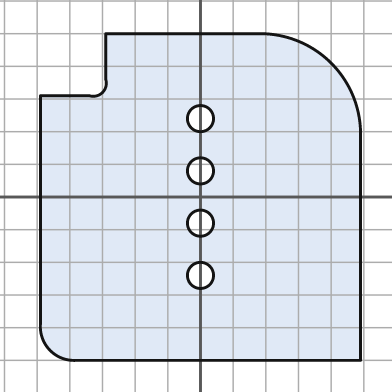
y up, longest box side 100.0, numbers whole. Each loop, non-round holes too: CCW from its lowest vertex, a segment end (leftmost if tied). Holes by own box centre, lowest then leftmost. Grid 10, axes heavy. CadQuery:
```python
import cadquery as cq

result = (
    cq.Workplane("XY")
    .moveTo(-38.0, -50.0)
    .lineTo(49.0, -50.0)
    .lineTo(49.0, 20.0)
    .threePointArc((40.0, 41.0), (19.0, 50.0))
    .lineTo(-29.0, 50.0)
    .lineTo(-29.0, 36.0)
    .threePointArc((-30.0, 32.0), (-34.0, 31.0))
    .lineTo(-49.0, 31.0)
    .lineTo(-49.0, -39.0)
    .threePointArc((-46.0, -47.0), (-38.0, -50.0))
    .close()
    .moveTo(0.0, -24.0)
    .circle(4.0)
    .moveTo(0.0, -8.0)
    .circle(4.0)
    .moveTo(0.0, 8.0)
    .circle(4.0)
    .moveTo(0.0, 24.0)
    .circle(4.0)
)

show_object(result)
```